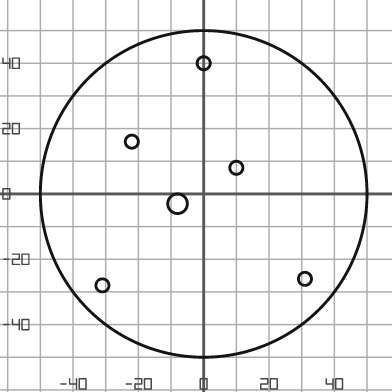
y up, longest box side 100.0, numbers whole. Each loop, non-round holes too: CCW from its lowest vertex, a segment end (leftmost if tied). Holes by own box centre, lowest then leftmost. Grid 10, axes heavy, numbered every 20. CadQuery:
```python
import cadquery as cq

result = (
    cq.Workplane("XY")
    .moveTo(0.0, 0.0)
    .circle(50.0)
    .moveTo(-31.0, -28.0)
    .circle(2.0)
    .moveTo(31.0, -26.0)
    .circle(2.0)
    .moveTo(-8.0, -3.0)
    .circle(3.0)
    .moveTo(10.0, 8.0)
    .circle(2.0)
    .moveTo(-22.0, 16.0)
    .circle(2.0)
    .moveTo(0.0, 40.0)
    .circle(2.0)
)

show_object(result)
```